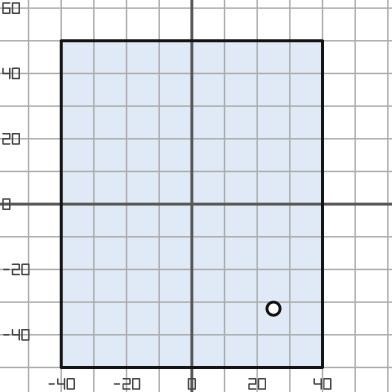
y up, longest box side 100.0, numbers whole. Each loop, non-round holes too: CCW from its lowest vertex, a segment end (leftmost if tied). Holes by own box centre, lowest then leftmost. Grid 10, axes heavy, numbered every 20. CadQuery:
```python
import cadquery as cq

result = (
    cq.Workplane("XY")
    .moveTo(-40.0, -50.0)
    .lineTo(40.0, -50.0)
    .lineTo(40.0, 50.0)
    .lineTo(-40.0, 50.0)
    .close()
    .moveTo(25.0, -32.0)
    .circle(2.0)
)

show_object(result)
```